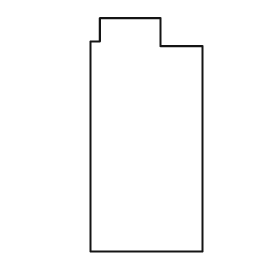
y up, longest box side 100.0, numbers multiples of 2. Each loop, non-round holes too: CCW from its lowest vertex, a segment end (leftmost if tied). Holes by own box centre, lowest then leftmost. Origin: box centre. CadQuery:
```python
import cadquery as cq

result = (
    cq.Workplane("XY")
    .moveTo(-24.0, -50.0)
    .lineTo(24.0, -50.0)
    .lineTo(24.0, 38.0)
    .lineTo(6.0, 38.0)
    .lineTo(6.0, 50.0)
    .lineTo(-20.0, 50.0)
    .lineTo(-20.0, 40.0)
    .lineTo(-24.0, 40.0)
    .close()
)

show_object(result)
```